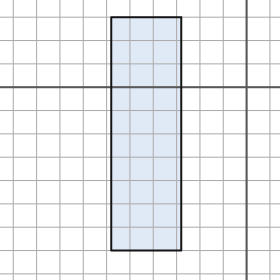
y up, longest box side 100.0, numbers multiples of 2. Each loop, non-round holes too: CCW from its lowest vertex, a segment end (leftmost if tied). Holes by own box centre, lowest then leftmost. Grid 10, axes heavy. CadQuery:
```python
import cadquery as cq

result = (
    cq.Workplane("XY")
    .moveTo(-58.0, -70.0)
    .lineTo(-28.0, -70.0)
    .lineTo(-28.0, 30.0)
    .lineTo(-58.0, 30.0)
    .close()
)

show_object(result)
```